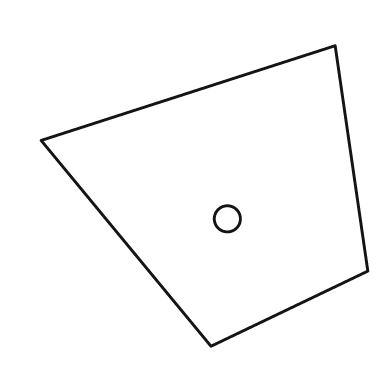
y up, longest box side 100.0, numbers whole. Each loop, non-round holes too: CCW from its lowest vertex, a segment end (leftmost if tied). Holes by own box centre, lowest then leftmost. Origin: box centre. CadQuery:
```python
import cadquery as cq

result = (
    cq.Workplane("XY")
    .moveTo(2.0, -46.0)
    .lineTo(50.0, -23.0)
    .lineTo(40.0, 46.0)
    .lineTo(-50.0, 17.0)
    .close()
    .moveTo(7.0, -7.0)
    .circle(4.0)
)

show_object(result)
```